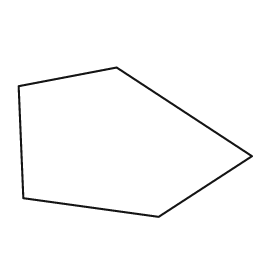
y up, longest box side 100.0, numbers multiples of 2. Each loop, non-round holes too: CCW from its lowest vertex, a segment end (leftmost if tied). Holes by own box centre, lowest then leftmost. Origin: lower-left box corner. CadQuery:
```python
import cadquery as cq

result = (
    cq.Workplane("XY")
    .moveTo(60.0, 0.0)
    .lineTo(100.0, 26.0)
    .lineTo(42.0, 64.0)
    .lineTo(0.0, 56.0)
    .lineTo(2.0, 8.0)
    .close()
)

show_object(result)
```